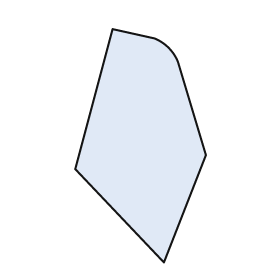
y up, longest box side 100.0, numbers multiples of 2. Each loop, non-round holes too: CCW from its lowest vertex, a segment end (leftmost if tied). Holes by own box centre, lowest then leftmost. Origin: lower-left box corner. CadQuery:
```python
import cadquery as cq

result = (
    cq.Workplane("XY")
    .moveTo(38.0, 0.0)
    .lineTo(56.0, 46.0)
    .lineTo(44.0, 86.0)
    .threePointArc((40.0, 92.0), (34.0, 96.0))
    .lineTo(16.0, 100.0)
    .lineTo(0.0, 40.0)
    .close()
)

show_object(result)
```